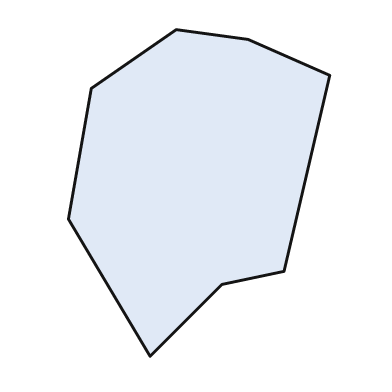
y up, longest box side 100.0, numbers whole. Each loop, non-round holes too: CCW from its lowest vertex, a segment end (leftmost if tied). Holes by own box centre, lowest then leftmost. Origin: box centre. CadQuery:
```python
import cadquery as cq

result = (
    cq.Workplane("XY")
    .moveTo(-15.0, -50.0)
    .lineTo(7.0, -28.0)
    .lineTo(26.0, -24.0)
    .lineTo(40.0, 36.0)
    .lineTo(15.0, 47.0)
    .lineTo(-7.0, 50.0)
    .lineTo(-33.0, 32.0)
    .lineTo(-40.0, -8.0)
    .close()
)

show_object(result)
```